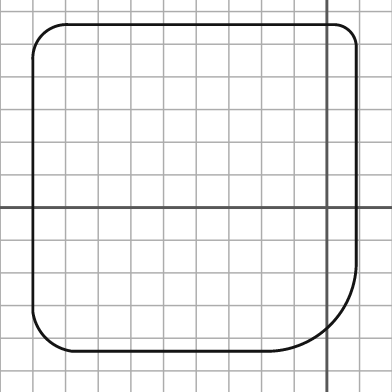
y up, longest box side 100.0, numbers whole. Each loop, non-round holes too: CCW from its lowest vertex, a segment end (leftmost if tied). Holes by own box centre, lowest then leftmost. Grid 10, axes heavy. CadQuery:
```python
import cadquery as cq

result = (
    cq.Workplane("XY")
    .moveTo(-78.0, -44.0)
    .lineTo(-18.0, -44.0)
    .threePointArc((1.0, -36.0), (9.0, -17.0))
    .lineTo(9.0, 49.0)
    .threePointArc((7.0, 54.0), (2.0, 56.0))
    .lineTo(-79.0, 56.0)
    .threePointArc((-87.0, 53.0), (-90.0, 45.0))
    .lineTo(-90.0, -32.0)
    .threePointArc((-86.0, -40.0), (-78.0, -44.0))
    .close()
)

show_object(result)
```